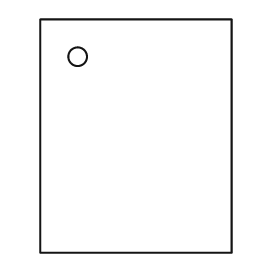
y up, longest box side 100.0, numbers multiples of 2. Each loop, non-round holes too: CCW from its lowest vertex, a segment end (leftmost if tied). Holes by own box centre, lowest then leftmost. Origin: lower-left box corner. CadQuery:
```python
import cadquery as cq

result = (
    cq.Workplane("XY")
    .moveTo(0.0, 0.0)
    .lineTo(82.0, 0.0)
    .lineTo(82.0, 100.0)
    .lineTo(0.0, 100.0)
    .close()
    .moveTo(16.0, 84.0)
    .circle(4.0)
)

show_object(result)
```